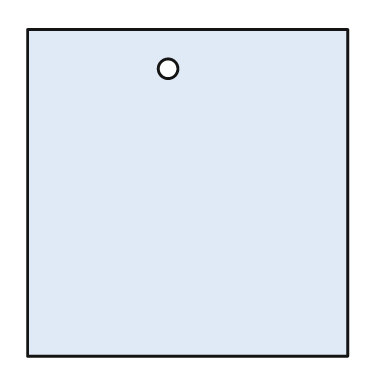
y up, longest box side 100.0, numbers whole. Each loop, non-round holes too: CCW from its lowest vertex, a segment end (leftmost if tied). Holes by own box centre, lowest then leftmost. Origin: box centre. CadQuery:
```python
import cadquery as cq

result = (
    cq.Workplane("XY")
    .moveTo(-49.0, -50.0)
    .lineTo(49.0, -50.0)
    .lineTo(49.0, 50.0)
    .lineTo(-49.0, 50.0)
    .close()
    .moveTo(-6.0, 38.0)
    .circle(3.0)
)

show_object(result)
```